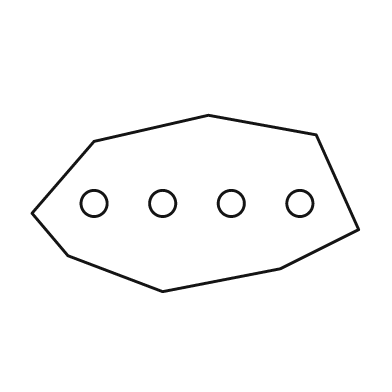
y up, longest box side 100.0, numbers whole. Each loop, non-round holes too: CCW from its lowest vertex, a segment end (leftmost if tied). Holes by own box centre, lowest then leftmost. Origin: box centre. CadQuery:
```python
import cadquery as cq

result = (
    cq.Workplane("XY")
    .moveTo(-10.0, -27.0)
    .lineTo(26.0, -20.0)
    .lineTo(50.0, -8.0)
    .lineTo(37.0, 21.0)
    .lineTo(4.0, 27.0)
    .lineTo(-31.0, 19.0)
    .lineTo(-50.0, -3.0)
    .lineTo(-39.0, -16.0)
    .close()
    .moveTo(-31.0, 0.0)
    .circle(4.0)
    .moveTo(-10.0, 0.0)
    .circle(4.0)
    .moveTo(11.0, 0.0)
    .circle(4.0)
    .moveTo(32.0, 0.0)
    .circle(4.0)
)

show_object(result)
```